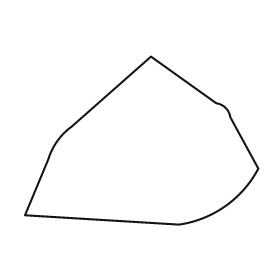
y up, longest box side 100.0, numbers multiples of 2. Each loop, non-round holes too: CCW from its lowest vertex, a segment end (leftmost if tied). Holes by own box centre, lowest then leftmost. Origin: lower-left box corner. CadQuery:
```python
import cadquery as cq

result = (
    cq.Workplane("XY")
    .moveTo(66.0, 0.0)
    .threePointArc((86.0, 8.0), (100.0, 24.0))
    .lineTo(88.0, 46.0)
    .threePointArc((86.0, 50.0), (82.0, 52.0))
    .lineTo(54.0, 72.0)
    .lineTo(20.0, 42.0)
    .threePointArc((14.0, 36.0), (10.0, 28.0))
    .lineTo(0.0, 4.0)
    .close()
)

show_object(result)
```